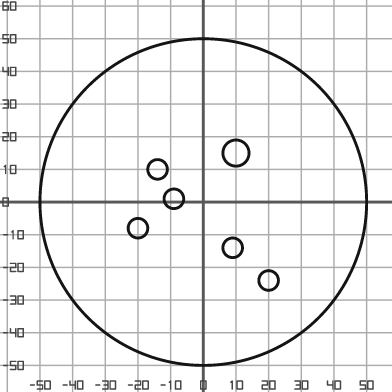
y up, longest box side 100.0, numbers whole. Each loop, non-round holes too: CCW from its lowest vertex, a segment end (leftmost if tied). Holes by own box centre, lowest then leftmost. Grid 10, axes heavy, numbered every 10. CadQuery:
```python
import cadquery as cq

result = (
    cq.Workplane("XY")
    .moveTo(0.0, 0.0)
    .circle(50.0)
    .moveTo(20.0, -24.0)
    .circle(3.0)
    .moveTo(9.0, -14.0)
    .circle(3.0)
    .moveTo(-20.0, -8.0)
    .circle(3.0)
    .moveTo(-9.0, 1.0)
    .circle(3.0)
    .moveTo(-14.0, 10.0)
    .circle(3.0)
    .moveTo(10.0, 15.0)
    .circle(4.0)
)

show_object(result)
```